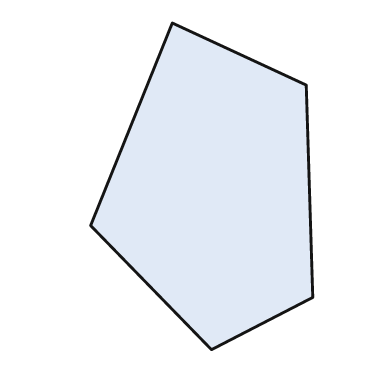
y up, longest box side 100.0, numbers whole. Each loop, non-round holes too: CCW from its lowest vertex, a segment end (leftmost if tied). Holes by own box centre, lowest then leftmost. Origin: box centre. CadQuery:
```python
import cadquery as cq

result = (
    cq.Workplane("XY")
    .moveTo(3.0, -50.0)
    .lineTo(34.0, -34.0)
    .lineTo(32.0, 31.0)
    .lineTo(-9.0, 50.0)
    .lineTo(-34.0, -12.0)
    .close()
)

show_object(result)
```